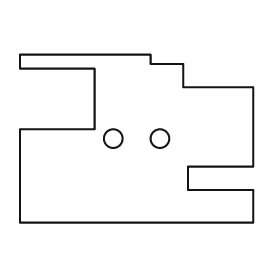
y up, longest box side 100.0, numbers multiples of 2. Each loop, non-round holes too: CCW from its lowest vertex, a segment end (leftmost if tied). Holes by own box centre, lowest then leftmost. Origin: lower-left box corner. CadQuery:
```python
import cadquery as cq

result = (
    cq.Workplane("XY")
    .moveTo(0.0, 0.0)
    .lineTo(100.0, 0.0)
    .lineTo(100.0, 14.0)
    .lineTo(72.0, 14.0)
    .lineTo(72.0, 24.0)
    .lineTo(100.0, 24.0)
    .lineTo(100.0, 58.0)
    .lineTo(70.0, 58.0)
    .lineTo(70.0, 68.0)
    .lineTo(56.0, 68.0)
    .lineTo(56.0, 72.0)
    .lineTo(0.0, 72.0)
    .lineTo(0.0, 66.0)
    .lineTo(32.0, 66.0)
    .lineTo(32.0, 40.0)
    .lineTo(0.0, 40.0)
    .close()
    .moveTo(40.0, 36.0)
    .circle(4.0)
    .moveTo(60.0, 36.0)
    .circle(4.0)
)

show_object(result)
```